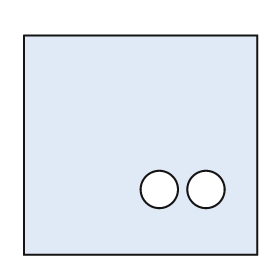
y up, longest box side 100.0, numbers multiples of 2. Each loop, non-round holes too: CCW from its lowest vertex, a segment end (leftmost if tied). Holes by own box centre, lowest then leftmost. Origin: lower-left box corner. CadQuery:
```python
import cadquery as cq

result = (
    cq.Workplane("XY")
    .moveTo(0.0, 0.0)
    .lineTo(100.0, 0.0)
    .lineTo(100.0, 94.0)
    .lineTo(0.0, 94.0)
    .close()
    .moveTo(58.0, 28.0)
    .circle(8.0)
    .moveTo(78.0, 28.0)
    .circle(8.0)
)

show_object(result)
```